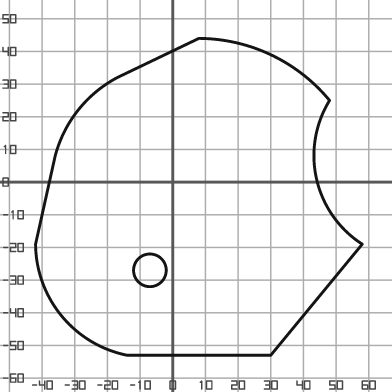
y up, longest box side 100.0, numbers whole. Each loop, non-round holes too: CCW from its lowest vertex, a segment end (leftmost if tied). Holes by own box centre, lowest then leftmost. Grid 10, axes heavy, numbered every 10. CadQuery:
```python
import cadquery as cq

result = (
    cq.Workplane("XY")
    .moveTo(-14.0, -53.0)
    .lineTo(30.0, -53.0)
    .lineTo(58.0, -19.0)
    .threePointArc((44.0, 1.0), (48.0, 25.0))
    .threePointArc((30.0, 39.0), (8.0, 44.0))
    .lineTo(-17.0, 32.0)
    .threePointArc((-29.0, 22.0), (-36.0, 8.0))
    .lineTo(-42.0, -19.0)
    .threePointArc((-34.0, -41.0), (-14.0, -53.0))
    .close()
    .moveTo(-7.0, -27.0)
    .circle(5.0)
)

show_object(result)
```